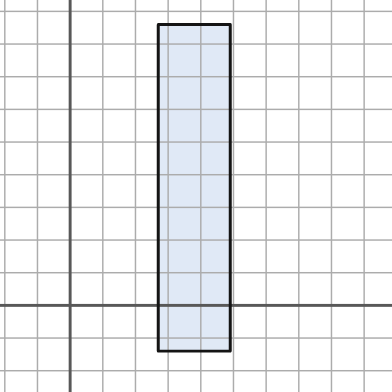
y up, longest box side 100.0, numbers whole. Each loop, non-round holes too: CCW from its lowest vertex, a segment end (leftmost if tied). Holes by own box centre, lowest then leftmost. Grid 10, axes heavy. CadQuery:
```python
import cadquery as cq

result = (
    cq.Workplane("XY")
    .moveTo(27.0, -14.0)
    .lineTo(49.0, -14.0)
    .lineTo(49.0, 86.0)
    .lineTo(27.0, 86.0)
    .close()
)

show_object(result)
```